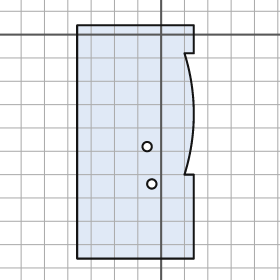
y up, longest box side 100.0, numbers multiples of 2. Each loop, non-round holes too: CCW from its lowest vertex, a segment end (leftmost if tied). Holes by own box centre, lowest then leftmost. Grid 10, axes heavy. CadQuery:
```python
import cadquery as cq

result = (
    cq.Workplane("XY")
    .moveTo(-36.0, -96.0)
    .lineTo(14.0, -96.0)
    .lineTo(14.0, -60.0)
    .lineTo(10.0, -60.0)
    .threePointArc((14.0, -34.0), (10.0, -8.0))
    .lineTo(14.0, -8.0)
    .lineTo(14.0, 4.0)
    .lineTo(-36.0, 4.0)
    .close()
    .moveTo(-4.0, -64.0)
    .circle(2.0)
    .moveTo(-6.0, -48.0)
    .circle(2.0)
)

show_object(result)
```